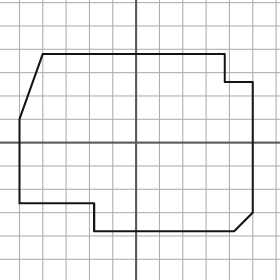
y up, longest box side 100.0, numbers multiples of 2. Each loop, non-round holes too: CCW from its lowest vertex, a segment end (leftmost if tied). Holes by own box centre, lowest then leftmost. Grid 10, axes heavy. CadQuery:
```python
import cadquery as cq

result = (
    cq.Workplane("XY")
    .moveTo(-18.0, -38.0)
    .lineTo(42.0, -38.0)
    .lineTo(50.0, -30.0)
    .lineTo(50.0, 26.0)
    .lineTo(38.0, 26.0)
    .lineTo(38.0, 38.0)
    .lineTo(-40.0, 38.0)
    .lineTo(-50.0, 10.0)
    .lineTo(-50.0, -26.0)
    .lineTo(-18.0, -26.0)
    .close()
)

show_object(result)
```